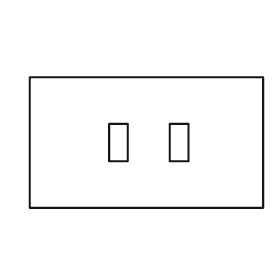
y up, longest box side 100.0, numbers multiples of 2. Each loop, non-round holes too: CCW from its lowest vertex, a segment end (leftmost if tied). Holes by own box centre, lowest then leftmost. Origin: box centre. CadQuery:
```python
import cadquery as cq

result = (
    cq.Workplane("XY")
    .moveTo(-50.0, -28.0)
    .lineTo(50.0, -28.0)
    .lineTo(50.0, 28.0)
    .lineTo(-50.0, 28.0)
    .close()
    .moveTo(-16.0, -8.0)
    .lineTo(-8.0, -8.0)
    .lineTo(-8.0, 8.0)
    .lineTo(-16.0, 8.0)
    .close()
    .moveTo(10.0, -8.0)
    .lineTo(18.0, -8.0)
    .lineTo(18.0, 8.0)
    .lineTo(10.0, 8.0)
    .close()
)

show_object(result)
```